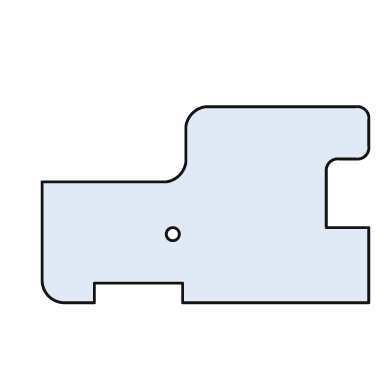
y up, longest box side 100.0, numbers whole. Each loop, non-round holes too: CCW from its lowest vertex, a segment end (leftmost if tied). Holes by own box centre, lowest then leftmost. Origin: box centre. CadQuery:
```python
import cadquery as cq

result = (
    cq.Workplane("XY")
    .moveTo(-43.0, -30.0)
    .lineTo(-34.0, -30.0)
    .lineTo(-34.0, -24.0)
    .lineTo(-7.0, -24.0)
    .lineTo(-7.0, -30.0)
    .lineTo(50.0, -30.0)
    .lineTo(50.0, -7.0)
    .lineTo(37.0, -7.0)
    .lineTo(37.0, 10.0)
    .threePointArc((38.0, 13.0), (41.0, 14.0))
    .lineTo(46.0, 14.0)
    .threePointArc((49.0, 15.0), (50.0, 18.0))
    .lineTo(50.0, 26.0)
    .threePointArc((49.0, 29.0), (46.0, 30.0))
    .lineTo(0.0, 30.0)
    .threePointArc((-4.0, 28.0), (-6.0, 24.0))
    .lineTo(-6.0, 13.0)
    .threePointArc((-8.0, 9.0), (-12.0, 7.0))
    .lineTo(-50.0, 7.0)
    .lineTo(-50.0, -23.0)
    .threePointArc((-48.0, -28.0), (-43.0, -30.0))
    .close()
    .moveTo(-10.0, -9.0)
    .circle(2.0)
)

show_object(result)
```